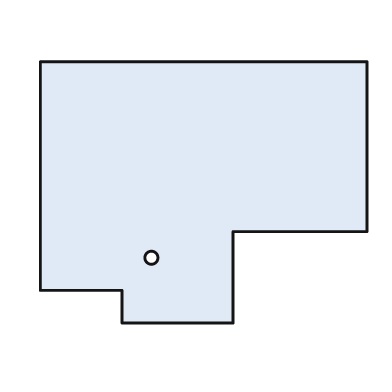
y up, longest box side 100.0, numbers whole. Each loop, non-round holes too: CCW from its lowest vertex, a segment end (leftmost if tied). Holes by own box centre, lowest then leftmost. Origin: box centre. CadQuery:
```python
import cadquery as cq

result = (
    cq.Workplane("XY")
    .moveTo(-25.0, -40.0)
    .lineTo(9.0, -40.0)
    .lineTo(9.0, -12.0)
    .lineTo(50.0, -12.0)
    .lineTo(50.0, 40.0)
    .lineTo(-50.0, 40.0)
    .lineTo(-50.0, -30.0)
    .lineTo(-25.0, -30.0)
    .close()
    .moveTo(-16.0, -20.0)
    .circle(2.0)
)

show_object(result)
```